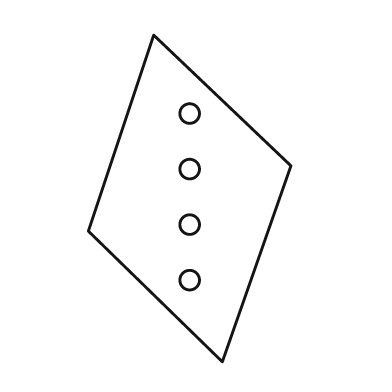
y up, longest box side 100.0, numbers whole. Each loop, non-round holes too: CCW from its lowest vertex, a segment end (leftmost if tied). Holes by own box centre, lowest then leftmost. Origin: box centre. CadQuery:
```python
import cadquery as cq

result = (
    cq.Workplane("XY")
    .moveTo(10.0, -50.0)
    .lineTo(31.0, 10.0)
    .lineTo(-11.0, 50.0)
    .lineTo(-31.0, -10.0)
    .close()
    .moveTo(0.0, -25.0)
    .circle(3.0)
    .moveTo(0.0, -8.0)
    .circle(3.0)
    .moveTo(0.0, 9.0)
    .circle(3.0)
    .moveTo(0.0, 26.0)
    .circle(3.0)
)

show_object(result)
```